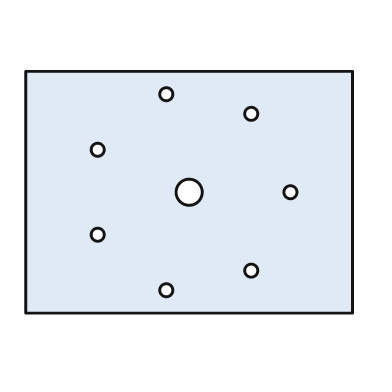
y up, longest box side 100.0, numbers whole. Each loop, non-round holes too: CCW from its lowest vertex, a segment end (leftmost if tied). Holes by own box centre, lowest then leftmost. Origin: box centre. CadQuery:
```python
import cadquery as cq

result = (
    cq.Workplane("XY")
    .moveTo(-50.0, -37.0)
    .lineTo(50.0, -37.0)
    .lineTo(50.0, 37.0)
    .lineTo(-50.0, 37.0)
    .close()
    .moveTo(-7.0, -30.0)
    .circle(2.0)
    .moveTo(19.0, -24.0)
    .circle(2.0)
    .moveTo(-28.0, -13.0)
    .circle(2.0)
    .moveTo(0.0, 0.0)
    .circle(4.0)
    .moveTo(31.0, 0.0)
    .circle(2.0)
    .moveTo(-28.0, 13.0)
    .circle(2.0)
    .moveTo(19.0, 24.0)
    .circle(2.0)
    .moveTo(-7.0, 30.0)
    .circle(2.0)
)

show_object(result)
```